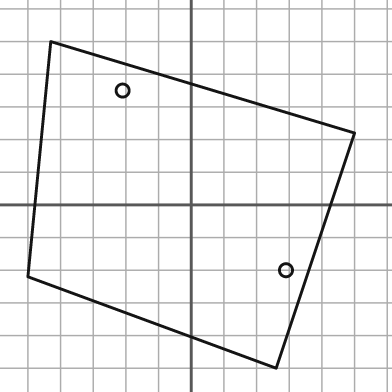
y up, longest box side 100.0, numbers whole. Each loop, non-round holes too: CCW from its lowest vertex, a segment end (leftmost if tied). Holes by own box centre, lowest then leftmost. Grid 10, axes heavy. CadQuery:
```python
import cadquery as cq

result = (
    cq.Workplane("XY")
    .moveTo(26.0, -50.0)
    .lineTo(50.0, 22.0)
    .lineTo(-43.0, 50.0)
    .lineTo(-50.0, -22.0)
    .close()
    .moveTo(29.0, -20.0)
    .circle(2.0)
    .moveTo(-21.0, 35.0)
    .circle(2.0)
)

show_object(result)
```